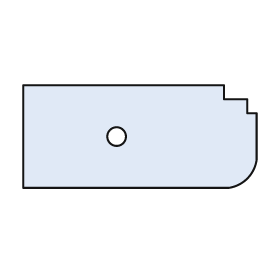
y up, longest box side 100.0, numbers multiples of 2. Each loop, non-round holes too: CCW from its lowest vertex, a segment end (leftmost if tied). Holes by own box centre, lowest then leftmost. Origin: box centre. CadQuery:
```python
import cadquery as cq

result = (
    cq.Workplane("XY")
    .moveTo(-50.0, -22.0)
    .lineTo(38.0, -22.0)
    .threePointArc((46.0, -18.0), (50.0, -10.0))
    .lineTo(50.0, 10.0)
    .lineTo(46.0, 10.0)
    .lineTo(46.0, 16.0)
    .lineTo(36.0, 16.0)
    .lineTo(36.0, 22.0)
    .lineTo(-50.0, 22.0)
    .close()
    .moveTo(-10.0, 0.0)
    .circle(4.0)
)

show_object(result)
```